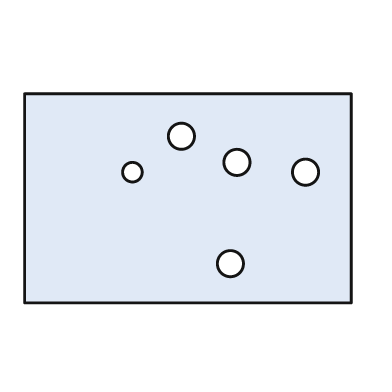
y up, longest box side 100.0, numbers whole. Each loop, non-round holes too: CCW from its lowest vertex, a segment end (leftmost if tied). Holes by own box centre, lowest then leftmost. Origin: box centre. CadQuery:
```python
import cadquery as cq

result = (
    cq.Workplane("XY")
    .moveTo(-50.0, -32.0)
    .lineTo(50.0, -32.0)
    .lineTo(50.0, 32.0)
    .lineTo(-50.0, 32.0)
    .close()
    .moveTo(13.0, -20.0)
    .circle(4.0)
    .moveTo(-17.0, 8.0)
    .circle(3.0)
    .moveTo(36.0, 8.0)
    .circle(4.0)
    .moveTo(15.0, 11.0)
    .circle(4.0)
    .moveTo(-2.0, 19.0)
    .circle(4.0)
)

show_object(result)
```